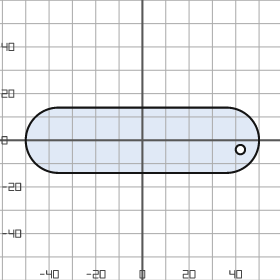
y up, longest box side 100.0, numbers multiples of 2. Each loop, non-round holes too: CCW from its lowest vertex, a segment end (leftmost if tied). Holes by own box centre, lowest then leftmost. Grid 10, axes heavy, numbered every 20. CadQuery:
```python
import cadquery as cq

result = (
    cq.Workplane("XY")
    .moveTo(-36.0, -14.0)
    .lineTo(36.0, -14.0)
    .threePointArc((50.0, 0.0), (36.0, 14.0))
    .lineTo(-36.0, 14.0)
    .threePointArc((-50.0, 0.0), (-36.0, -14.0))
    .close()
    .moveTo(42.0, -4.0)
    .circle(2.0)
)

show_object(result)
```